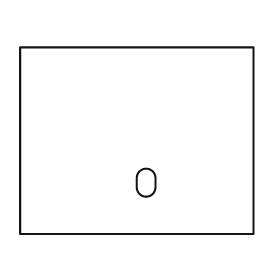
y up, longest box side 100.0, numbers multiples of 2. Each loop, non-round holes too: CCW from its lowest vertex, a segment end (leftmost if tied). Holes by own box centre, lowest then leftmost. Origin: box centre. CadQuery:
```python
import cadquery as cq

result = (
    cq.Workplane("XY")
    .moveTo(-50.0, -40.0)
    .lineTo(50.0, -40.0)
    .lineTo(50.0, 40.0)
    .lineTo(-50.0, 40.0)
    .close()
    .moveTo(0.0, -20.0)
    .threePointArc((4.0, -24.0), (8.0, -20.0))
    .lineTo(8.0, -16.0)
    .threePointArc((4.0, -12.0), (0.0, -16.0))
    .close()
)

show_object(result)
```